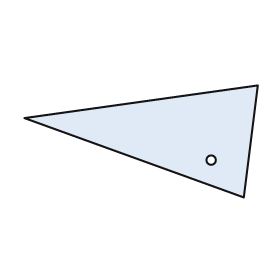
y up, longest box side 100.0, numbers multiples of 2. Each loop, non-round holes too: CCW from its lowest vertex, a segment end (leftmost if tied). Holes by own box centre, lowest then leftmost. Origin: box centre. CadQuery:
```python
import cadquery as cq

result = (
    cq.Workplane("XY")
    .moveTo(44.0, -24.0)
    .lineTo(50.0, 24.0)
    .lineTo(-50.0, 10.0)
    .close()
    .moveTo(30.0, -8.0)
    .circle(2.0)
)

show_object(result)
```